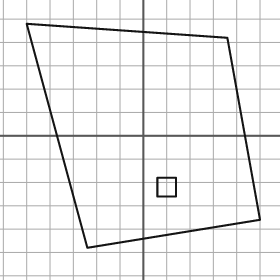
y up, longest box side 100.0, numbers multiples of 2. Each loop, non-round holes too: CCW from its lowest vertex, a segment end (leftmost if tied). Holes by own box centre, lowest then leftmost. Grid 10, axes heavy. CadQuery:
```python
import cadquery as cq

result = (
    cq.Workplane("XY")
    .moveTo(-24.0, -48.0)
    .lineTo(50.0, -36.0)
    .lineTo(36.0, 42.0)
    .lineTo(-50.0, 48.0)
    .close()
    .moveTo(6.0, -26.0)
    .lineTo(14.0, -26.0)
    .lineTo(14.0, -18.0)
    .lineTo(6.0, -18.0)
    .close()
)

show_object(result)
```